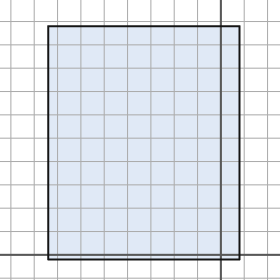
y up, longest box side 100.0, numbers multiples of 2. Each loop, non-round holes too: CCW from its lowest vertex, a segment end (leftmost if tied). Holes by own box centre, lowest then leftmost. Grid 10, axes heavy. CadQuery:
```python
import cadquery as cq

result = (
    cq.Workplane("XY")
    .moveTo(-74.0, -2.0)
    .lineTo(8.0, -2.0)
    .lineTo(8.0, 98.0)
    .lineTo(-74.0, 98.0)
    .close()
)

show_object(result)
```